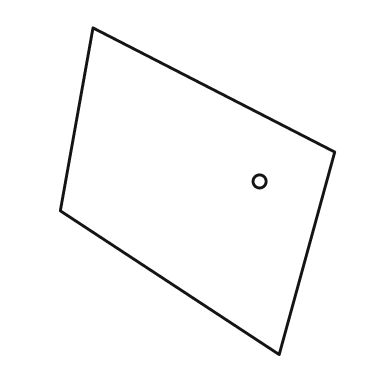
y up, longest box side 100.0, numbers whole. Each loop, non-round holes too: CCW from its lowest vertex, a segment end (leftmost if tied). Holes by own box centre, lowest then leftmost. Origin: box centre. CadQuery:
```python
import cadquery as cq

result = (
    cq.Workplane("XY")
    .moveTo(25.0, -50.0)
    .lineTo(42.0, 12.0)
    .lineTo(-32.0, 50.0)
    .lineTo(-42.0, -6.0)
    .close()
    .moveTo(19.0, 3.0)
    .circle(2.0)
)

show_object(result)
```